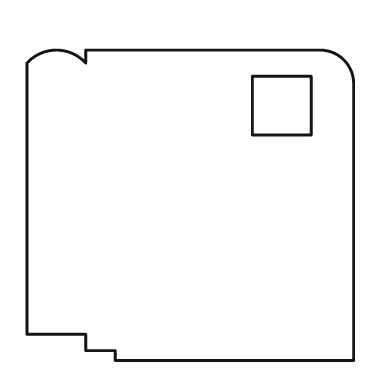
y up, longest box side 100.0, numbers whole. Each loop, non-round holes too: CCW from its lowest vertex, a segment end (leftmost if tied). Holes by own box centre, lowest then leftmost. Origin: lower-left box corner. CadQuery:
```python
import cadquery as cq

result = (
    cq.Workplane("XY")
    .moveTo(27.0, 0.0)
    .lineTo(100.0, 0.0)
    .lineTo(100.0, 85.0)
    .threePointArc((97.0, 92.0), (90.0, 95.0))
    .lineTo(18.0, 95.0)
    .lineTo(18.0, 91.0)
    .threePointArc((9.0, 95.0), (0.0, 91.0))
    .lineTo(0.0, 8.0)
    .lineTo(18.0, 8.0)
    .lineTo(18.0, 3.0)
    .lineTo(27.0, 3.0)
    .close()
    .moveTo(69.0, 69.0)
    .lineTo(87.0, 69.0)
    .lineTo(87.0, 87.0)
    .lineTo(69.0, 87.0)
    .close()
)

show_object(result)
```